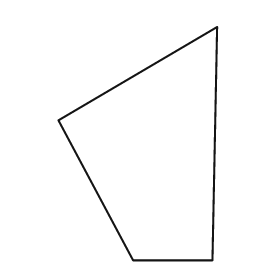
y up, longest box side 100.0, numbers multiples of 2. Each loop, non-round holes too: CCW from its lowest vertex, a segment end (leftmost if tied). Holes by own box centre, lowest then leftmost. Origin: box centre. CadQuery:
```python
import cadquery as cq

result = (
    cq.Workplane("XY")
    .moveTo(-2.0, -50.0)
    .lineTo(32.0, -50.0)
    .lineTo(34.0, 50.0)
    .lineTo(-34.0, 10.0)
    .close()
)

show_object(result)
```